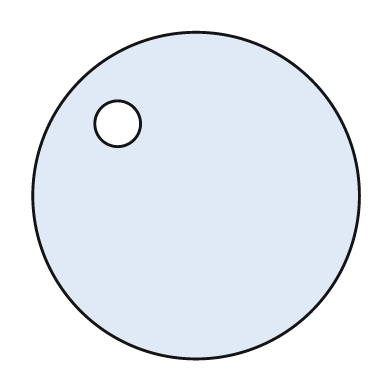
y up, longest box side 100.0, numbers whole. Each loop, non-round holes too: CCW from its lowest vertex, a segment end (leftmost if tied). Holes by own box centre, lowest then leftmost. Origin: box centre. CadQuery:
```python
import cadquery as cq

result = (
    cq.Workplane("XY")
    .moveTo(0.0, 0.0)
    .circle(50.0)
    .moveTo(-24.0, 22.0)
    .circle(7.0)
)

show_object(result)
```